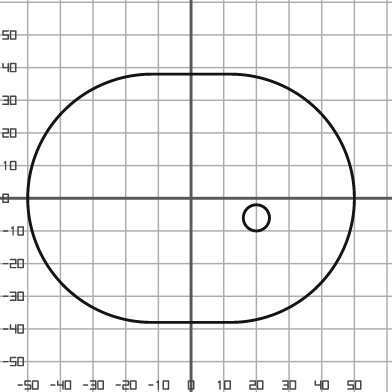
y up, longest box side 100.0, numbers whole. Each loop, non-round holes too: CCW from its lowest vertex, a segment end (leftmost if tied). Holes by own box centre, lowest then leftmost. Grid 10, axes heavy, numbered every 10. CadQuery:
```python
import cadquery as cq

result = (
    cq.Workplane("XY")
    .moveTo(-12.0, -38.0)
    .lineTo(12.0, -38.0)
    .threePointArc((50.0, 0.0), (12.0, 38.0))
    .lineTo(-12.0, 38.0)
    .threePointArc((-50.0, 0.0), (-12.0, -38.0))
    .close()
    .moveTo(20.0, -6.0)
    .circle(4.0)
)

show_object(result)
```